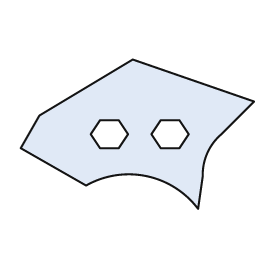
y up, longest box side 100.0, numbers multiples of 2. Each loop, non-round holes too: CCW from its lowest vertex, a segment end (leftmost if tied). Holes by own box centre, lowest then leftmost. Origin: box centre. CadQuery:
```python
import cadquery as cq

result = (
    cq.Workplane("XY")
    .moveTo(26.0, -32.0)
    .lineTo(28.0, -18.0)
    .threePointArc((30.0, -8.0), (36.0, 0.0))
    .lineTo(50.0, 14.0)
    .lineTo(-2.0, 32.0)
    .lineTo(-42.0, 8.0)
    .lineTo(-50.0, -6.0)
    .lineTo(-22.0, -22.0)
    .threePointArc((4.0, -18.0), (26.0, -32.0))
    .close()
    .moveTo(-16.0, -6.0)
    .lineTo(-8.0, -6.0)
    .lineTo(-4.0, 0.0)
    .lineTo(-8.0, 6.0)
    .lineTo(-16.0, 6.0)
    .lineTo(-20.0, 0.0)
    .close()
    .moveTo(10.0, -6.0)
    .lineTo(18.0, -6.0)
    .lineTo(22.0, 0.0)
    .lineTo(18.0, 6.0)
    .lineTo(10.0, 6.0)
    .lineTo(6.0, 0.0)
    .close()
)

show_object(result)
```